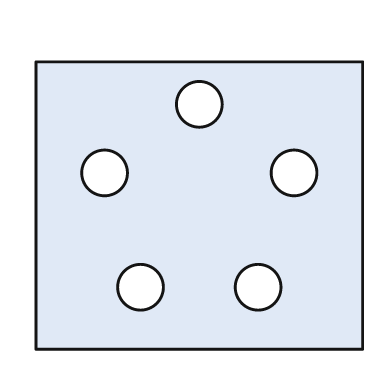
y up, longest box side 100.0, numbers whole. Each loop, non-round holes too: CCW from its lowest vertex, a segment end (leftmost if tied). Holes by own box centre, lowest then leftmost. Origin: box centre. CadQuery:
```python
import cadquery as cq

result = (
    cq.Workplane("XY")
    .moveTo(-50.0, -44.0)
    .lineTo(50.0, -44.0)
    .lineTo(50.0, 44.0)
    .lineTo(-50.0, 44.0)
    .close()
    .moveTo(-18.0, -25.0)
    .circle(7.0)
    .moveTo(18.0, -25.0)
    .circle(7.0)
    .moveTo(-29.0, 10.0)
    .circle(7.0)
    .moveTo(29.0, 10.0)
    .circle(7.0)
    .moveTo(0.0, 31.0)
    .circle(7.0)
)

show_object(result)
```